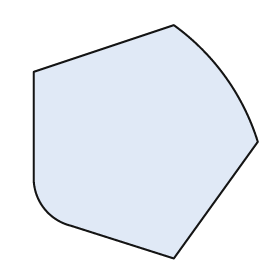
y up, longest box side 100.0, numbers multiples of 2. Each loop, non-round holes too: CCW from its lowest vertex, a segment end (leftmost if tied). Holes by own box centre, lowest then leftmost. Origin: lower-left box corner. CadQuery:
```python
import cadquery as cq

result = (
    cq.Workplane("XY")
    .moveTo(60.0, 0.0)
    .lineTo(96.0, 50.0)
    .threePointArc((82.0, 78.0), (60.0, 100.0))
    .lineTo(0.0, 80.0)
    .lineTo(0.0, 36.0)
    .threePointArc((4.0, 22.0), (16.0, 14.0))
    .close()
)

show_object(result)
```